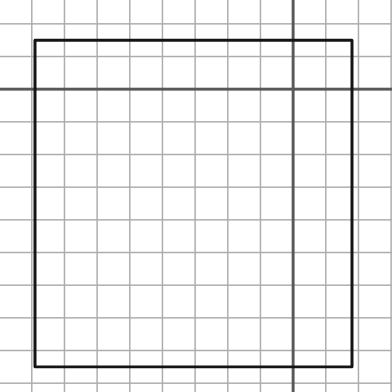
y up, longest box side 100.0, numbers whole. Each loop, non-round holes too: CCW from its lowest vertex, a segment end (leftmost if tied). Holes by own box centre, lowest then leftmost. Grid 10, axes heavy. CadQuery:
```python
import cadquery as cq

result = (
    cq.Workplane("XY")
    .moveTo(-79.0, -85.0)
    .lineTo(18.0, -85.0)
    .lineTo(18.0, 15.0)
    .lineTo(-79.0, 15.0)
    .close()
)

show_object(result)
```